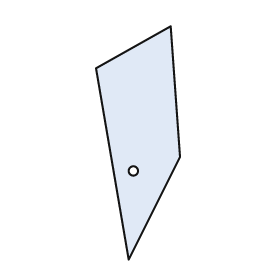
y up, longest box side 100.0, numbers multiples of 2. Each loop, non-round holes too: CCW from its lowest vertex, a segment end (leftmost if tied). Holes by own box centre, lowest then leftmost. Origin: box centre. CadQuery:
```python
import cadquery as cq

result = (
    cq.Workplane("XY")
    .moveTo(-4.0, -50.0)
    .lineTo(18.0, -6.0)
    .lineTo(14.0, 50.0)
    .lineTo(-18.0, 32.0)
    .close()
    .moveTo(-2.0, -12.0)
    .circle(2.0)
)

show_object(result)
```